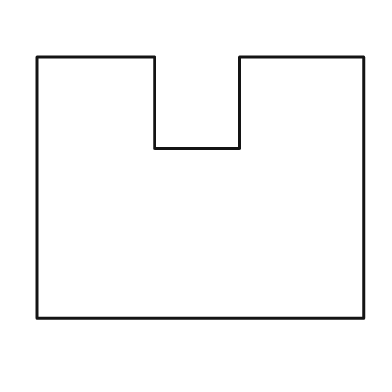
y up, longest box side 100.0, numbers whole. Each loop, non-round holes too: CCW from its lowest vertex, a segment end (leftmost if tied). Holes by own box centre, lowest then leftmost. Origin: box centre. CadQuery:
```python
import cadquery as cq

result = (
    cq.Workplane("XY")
    .moveTo(-50.0, -40.0)
    .lineTo(50.0, -40.0)
    .lineTo(50.0, 40.0)
    .lineTo(12.0, 40.0)
    .lineTo(12.0, 12.0)
    .lineTo(-14.0, 12.0)
    .lineTo(-14.0, 40.0)
    .lineTo(-50.0, 40.0)
    .close()
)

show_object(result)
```